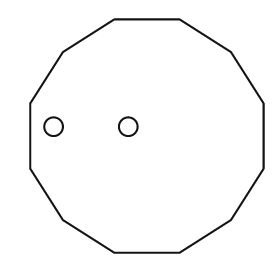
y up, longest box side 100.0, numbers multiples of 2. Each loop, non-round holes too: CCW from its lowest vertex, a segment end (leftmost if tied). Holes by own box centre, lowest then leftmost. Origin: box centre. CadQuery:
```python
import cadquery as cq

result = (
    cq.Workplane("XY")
    .moveTo(-14.0, -50.0)
    .lineTo(14.0, -50.0)
    .lineTo(36.0, -36.0)
    .lineTo(50.0, -14.0)
    .lineTo(50.0, 14.0)
    .lineTo(36.0, 36.0)
    .lineTo(14.0, 50.0)
    .lineTo(-14.0, 50.0)
    .lineTo(-36.0, 36.0)
    .lineTo(-50.0, 14.0)
    .lineTo(-50.0, -14.0)
    .lineTo(-36.0, -36.0)
    .close()
    .moveTo(-40.0, 4.0)
    .circle(4.0)
    .moveTo(-8.0, 4.0)
    .circle(4.0)
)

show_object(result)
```